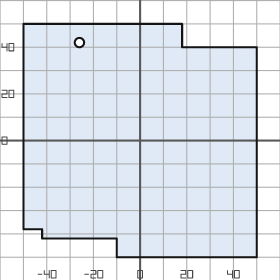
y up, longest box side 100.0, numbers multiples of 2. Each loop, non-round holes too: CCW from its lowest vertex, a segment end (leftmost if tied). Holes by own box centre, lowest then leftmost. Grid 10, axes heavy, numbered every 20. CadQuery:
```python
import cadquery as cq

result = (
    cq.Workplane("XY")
    .moveTo(-10.0, -50.0)
    .lineTo(50.0, -50.0)
    .lineTo(50.0, 40.0)
    .lineTo(18.0, 40.0)
    .lineTo(18.0, 50.0)
    .lineTo(-50.0, 50.0)
    .lineTo(-50.0, -38.0)
    .lineTo(-42.0, -38.0)
    .lineTo(-42.0, -42.0)
    .lineTo(-10.0, -42.0)
    .close()
    .moveTo(-26.0, 42.0)
    .circle(2.0)
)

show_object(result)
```